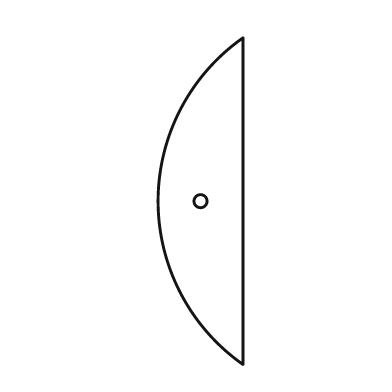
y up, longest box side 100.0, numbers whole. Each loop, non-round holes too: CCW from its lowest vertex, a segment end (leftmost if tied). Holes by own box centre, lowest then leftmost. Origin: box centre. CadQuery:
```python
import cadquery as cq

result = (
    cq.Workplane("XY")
    .moveTo(13.0, -50.0)
    .lineTo(13.0, 50.0)
    .threePointArc((-13.0, 0.0), (13.0, -50.0))
    .close()
    .moveTo(0.0, 0.0)
    .circle(2.0)
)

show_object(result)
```